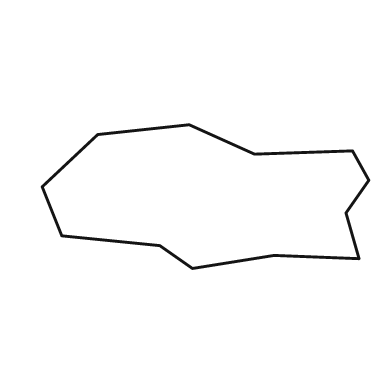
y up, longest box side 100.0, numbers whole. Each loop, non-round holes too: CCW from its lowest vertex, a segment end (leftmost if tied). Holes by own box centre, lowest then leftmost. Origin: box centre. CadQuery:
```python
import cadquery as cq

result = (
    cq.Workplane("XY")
    .moveTo(-4.0, -22.0)
    .lineTo(21.0, -18.0)
    .lineTo(47.0, -19.0)
    .lineTo(43.0, -5.0)
    .lineTo(50.0, 5.0)
    .lineTo(45.0, 14.0)
    .lineTo(15.0, 13.0)
    .lineTo(-5.0, 22.0)
    .lineTo(-33.0, 19.0)
    .lineTo(-50.0, 3.0)
    .lineTo(-44.0, -12.0)
    .lineTo(-14.0, -15.0)
    .close()
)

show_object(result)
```